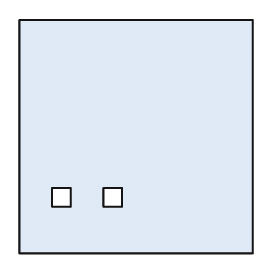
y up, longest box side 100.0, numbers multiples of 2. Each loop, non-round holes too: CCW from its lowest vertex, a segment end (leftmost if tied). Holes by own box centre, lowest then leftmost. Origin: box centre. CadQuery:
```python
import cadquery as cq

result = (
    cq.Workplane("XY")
    .moveTo(-50.0, -50.0)
    .lineTo(50.0, -50.0)
    .lineTo(50.0, 50.0)
    .lineTo(-50.0, 50.0)
    .close()
    .moveTo(-36.0, -30.0)
    .lineTo(-28.0, -30.0)
    .lineTo(-28.0, -22.0)
    .lineTo(-36.0, -22.0)
    .close()
    .moveTo(-14.0, -30.0)
    .lineTo(-6.0, -30.0)
    .lineTo(-6.0, -22.0)
    .lineTo(-14.0, -22.0)
    .close()
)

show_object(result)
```